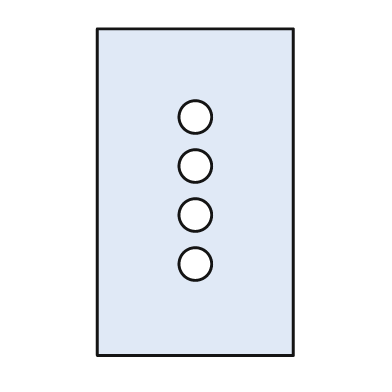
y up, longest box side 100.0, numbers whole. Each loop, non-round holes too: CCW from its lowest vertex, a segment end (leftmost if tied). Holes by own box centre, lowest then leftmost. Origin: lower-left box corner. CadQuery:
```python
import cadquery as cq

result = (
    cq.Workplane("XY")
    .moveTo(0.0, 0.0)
    .lineTo(60.0, 0.0)
    .lineTo(60.0, 100.0)
    .lineTo(0.0, 100.0)
    .close()
    .moveTo(30.0, 28.0)
    .circle(5.0)
    .moveTo(30.0, 43.0)
    .circle(5.0)
    .moveTo(30.0, 58.0)
    .circle(5.0)
    .moveTo(30.0, 73.0)
    .circle(5.0)
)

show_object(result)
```